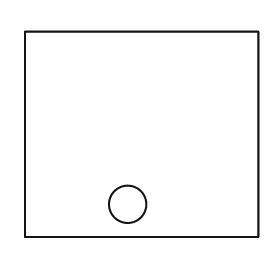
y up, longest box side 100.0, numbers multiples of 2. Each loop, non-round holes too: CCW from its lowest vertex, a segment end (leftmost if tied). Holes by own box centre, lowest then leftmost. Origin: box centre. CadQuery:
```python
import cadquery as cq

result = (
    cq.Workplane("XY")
    .moveTo(-50.0, -44.0)
    .lineTo(50.0, -44.0)
    .lineTo(50.0, 44.0)
    .lineTo(-50.0, 44.0)
    .close()
    .moveTo(-6.0, -30.0)
    .circle(8.0)
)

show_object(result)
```